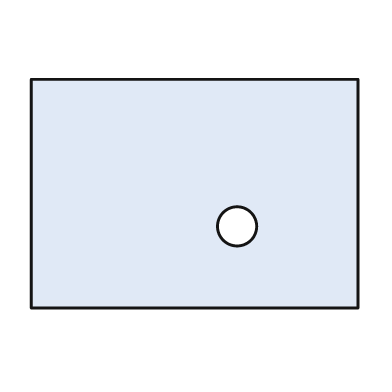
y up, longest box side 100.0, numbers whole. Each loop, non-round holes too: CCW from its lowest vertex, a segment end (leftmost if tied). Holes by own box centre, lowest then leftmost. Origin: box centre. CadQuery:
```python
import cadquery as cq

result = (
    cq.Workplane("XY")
    .moveTo(-50.0, -35.0)
    .lineTo(50.0, -35.0)
    .lineTo(50.0, 35.0)
    .lineTo(-50.0, 35.0)
    .close()
    .moveTo(13.0, -10.0)
    .circle(6.0)
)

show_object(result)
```